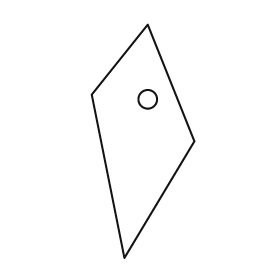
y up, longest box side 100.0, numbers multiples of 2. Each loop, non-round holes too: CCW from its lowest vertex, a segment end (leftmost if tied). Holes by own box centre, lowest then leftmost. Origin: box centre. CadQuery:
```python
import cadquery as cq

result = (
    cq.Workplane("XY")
    .moveTo(-8.0, -50.0)
    .lineTo(22.0, 0.0)
    .lineTo(2.0, 50.0)
    .lineTo(-22.0, 20.0)
    .close()
    .moveTo(2.0, 18.0)
    .circle(4.0)
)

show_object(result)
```